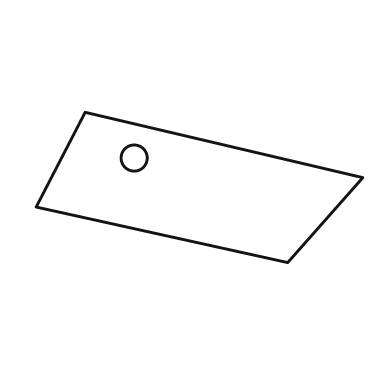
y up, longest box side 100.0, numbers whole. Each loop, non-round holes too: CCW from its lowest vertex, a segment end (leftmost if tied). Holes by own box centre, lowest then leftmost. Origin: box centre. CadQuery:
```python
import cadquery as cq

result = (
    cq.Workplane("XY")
    .moveTo(27.0, -23.0)
    .lineTo(50.0, 3.0)
    .lineTo(-35.0, 23.0)
    .lineTo(-50.0, -6.0)
    .close()
    .moveTo(-20.0, 9.0)
    .circle(4.0)
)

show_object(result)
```